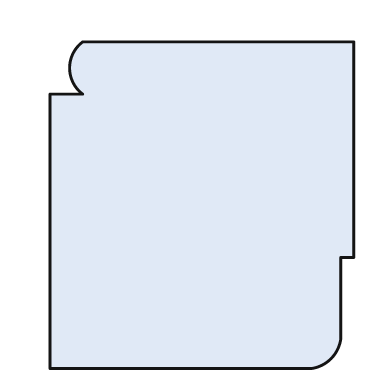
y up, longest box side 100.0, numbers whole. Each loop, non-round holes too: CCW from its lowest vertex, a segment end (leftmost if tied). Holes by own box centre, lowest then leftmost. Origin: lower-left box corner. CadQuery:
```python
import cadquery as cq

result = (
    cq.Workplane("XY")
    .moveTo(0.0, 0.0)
    .lineTo(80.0, 0.0)
    .threePointArc((86.0, 3.0), (89.0, 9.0))
    .lineTo(89.0, 34.0)
    .lineTo(93.0, 34.0)
    .lineTo(93.0, 100.0)
    .lineTo(10.0, 100.0)
    .threePointArc((6.0, 92.0), (10.0, 84.0))
    .lineTo(0.0, 84.0)
    .close()
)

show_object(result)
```